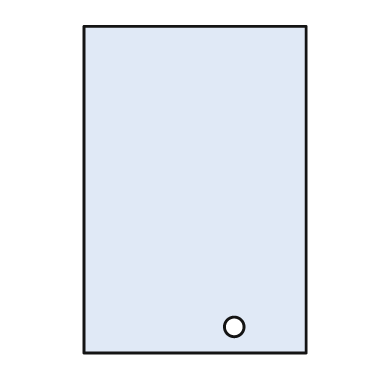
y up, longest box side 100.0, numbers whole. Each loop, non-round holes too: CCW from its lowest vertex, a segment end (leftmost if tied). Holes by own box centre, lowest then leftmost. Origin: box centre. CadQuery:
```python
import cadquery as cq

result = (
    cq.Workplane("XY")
    .moveTo(-34.0, -50.0)
    .lineTo(34.0, -50.0)
    .lineTo(34.0, 50.0)
    .lineTo(-34.0, 50.0)
    .close()
    .moveTo(12.0, -42.0)
    .circle(3.0)
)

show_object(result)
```